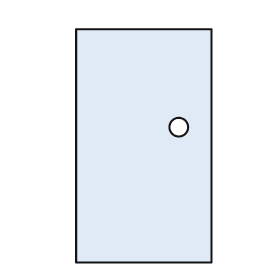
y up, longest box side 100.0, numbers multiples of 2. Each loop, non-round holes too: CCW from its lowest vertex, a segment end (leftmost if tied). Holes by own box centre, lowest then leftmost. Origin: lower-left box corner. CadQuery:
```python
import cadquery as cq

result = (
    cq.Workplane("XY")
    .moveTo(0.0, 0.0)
    .lineTo(58.0, 0.0)
    .lineTo(58.0, 100.0)
    .lineTo(0.0, 100.0)
    .close()
    .moveTo(44.0, 58.0)
    .circle(4.0)
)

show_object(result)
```